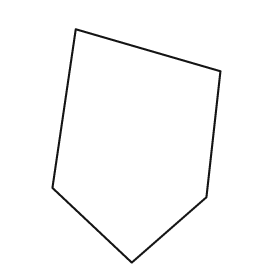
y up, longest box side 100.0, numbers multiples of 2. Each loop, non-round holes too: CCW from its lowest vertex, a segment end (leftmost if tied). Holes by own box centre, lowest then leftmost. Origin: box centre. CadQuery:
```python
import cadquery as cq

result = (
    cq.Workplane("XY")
    .moveTo(-2.0, -50.0)
    .lineTo(30.0, -22.0)
    .lineTo(36.0, 32.0)
    .lineTo(-26.0, 50.0)
    .lineTo(-36.0, -18.0)
    .close()
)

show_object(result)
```